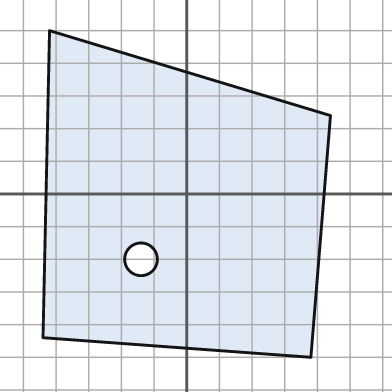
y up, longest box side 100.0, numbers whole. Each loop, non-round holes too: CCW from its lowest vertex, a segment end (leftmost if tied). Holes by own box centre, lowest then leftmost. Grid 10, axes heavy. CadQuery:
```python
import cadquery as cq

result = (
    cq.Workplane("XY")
    .moveTo(38.0, -50.0)
    .lineTo(44.0, 24.0)
    .lineTo(-42.0, 50.0)
    .lineTo(-44.0, -44.0)
    .close()
    .moveTo(-14.0, -20.0)
    .circle(5.0)
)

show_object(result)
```